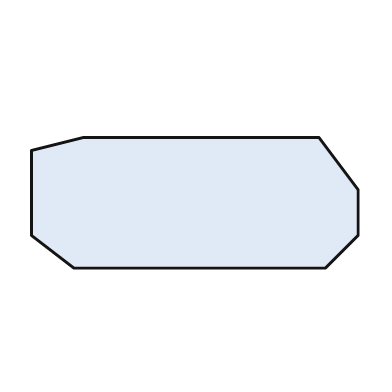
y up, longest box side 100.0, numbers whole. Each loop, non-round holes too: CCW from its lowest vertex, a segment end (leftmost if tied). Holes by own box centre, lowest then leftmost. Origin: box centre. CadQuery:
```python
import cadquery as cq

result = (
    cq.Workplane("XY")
    .moveTo(-37.0, -20.0)
    .lineTo(40.0, -20.0)
    .lineTo(50.0, -10.0)
    .lineTo(50.0, 4.0)
    .lineTo(38.0, 20.0)
    .lineTo(-34.0, 20.0)
    .lineTo(-50.0, 16.0)
    .lineTo(-50.0, -10.0)
    .close()
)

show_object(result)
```